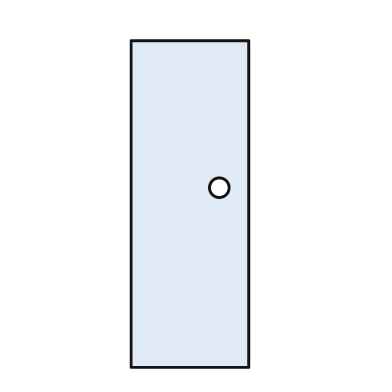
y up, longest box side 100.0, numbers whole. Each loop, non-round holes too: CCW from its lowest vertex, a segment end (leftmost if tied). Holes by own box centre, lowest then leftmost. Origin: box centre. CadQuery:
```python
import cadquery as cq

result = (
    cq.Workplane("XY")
    .moveTo(-18.0, -50.0)
    .lineTo(18.0, -50.0)
    .lineTo(18.0, 50.0)
    .lineTo(-18.0, 50.0)
    .close()
    .moveTo(9.0, 5.0)
    .circle(3.0)
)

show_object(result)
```